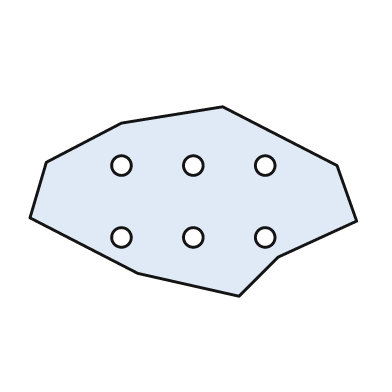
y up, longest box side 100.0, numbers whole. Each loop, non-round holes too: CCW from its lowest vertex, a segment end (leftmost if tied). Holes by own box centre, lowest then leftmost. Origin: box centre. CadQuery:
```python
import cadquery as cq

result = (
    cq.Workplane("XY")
    .moveTo(14.0, -29.0)
    .lineTo(26.0, -17.0)
    .lineTo(50.0, -6.0)
    .lineTo(44.0, 11.0)
    .lineTo(9.0, 29.0)
    .lineTo(-22.0, 24.0)
    .lineTo(-45.0, 12.0)
    .lineTo(-50.0, -5.0)
    .lineTo(-17.0, -22.0)
    .close()
    .moveTo(-22.0, -11.0)
    .circle(3.0)
    .moveTo(0.0, -11.0)
    .circle(3.0)
    .moveTo(22.0, -11.0)
    .circle(3.0)
    .moveTo(-22.0, 11.0)
    .circle(3.0)
    .moveTo(0.0, 11.0)
    .circle(3.0)
    .moveTo(22.0, 11.0)
    .circle(3.0)
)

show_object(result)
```